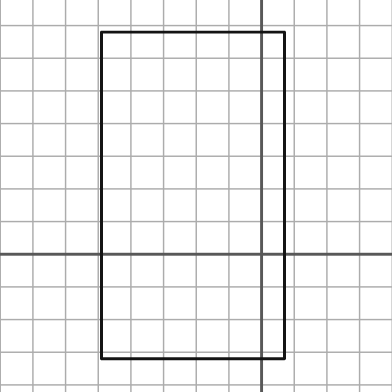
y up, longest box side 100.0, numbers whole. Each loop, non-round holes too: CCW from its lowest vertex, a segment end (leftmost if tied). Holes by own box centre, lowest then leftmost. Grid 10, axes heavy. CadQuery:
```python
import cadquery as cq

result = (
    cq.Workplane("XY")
    .moveTo(-49.0, -32.0)
    .lineTo(7.0, -32.0)
    .lineTo(7.0, 68.0)
    .lineTo(-49.0, 68.0)
    .close()
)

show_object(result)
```